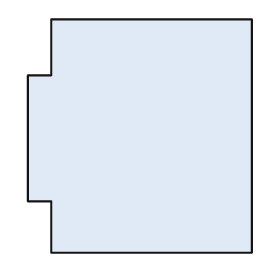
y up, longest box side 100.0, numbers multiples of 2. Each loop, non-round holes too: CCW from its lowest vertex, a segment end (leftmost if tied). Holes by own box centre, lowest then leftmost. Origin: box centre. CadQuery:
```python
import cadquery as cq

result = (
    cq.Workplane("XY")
    .moveTo(-38.0, -50.0)
    .lineTo(48.0, -50.0)
    .lineTo(48.0, 50.0)
    .lineTo(-38.0, 50.0)
    .lineTo(-38.0, 26.0)
    .lineTo(-48.0, 26.0)
    .lineTo(-48.0, -28.0)
    .lineTo(-38.0, -28.0)
    .close()
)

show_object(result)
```